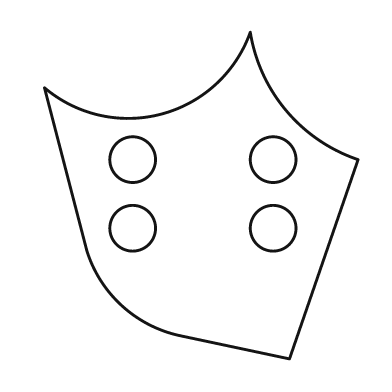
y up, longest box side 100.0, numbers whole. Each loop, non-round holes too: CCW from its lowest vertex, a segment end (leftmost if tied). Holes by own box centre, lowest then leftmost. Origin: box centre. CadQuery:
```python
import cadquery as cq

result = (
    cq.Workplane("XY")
    .moveTo(27.0, -50.0)
    .lineTo(48.0, 11.0)
    .threePointArc((26.0, 26.0), (15.0, 50.0))
    .threePointArc((-12.0, 25.0), (-48.0, 33.0))
    .lineTo(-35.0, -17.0)
    .threePointArc((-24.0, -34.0), (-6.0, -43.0))
    .close()
    .moveTo(-21.0, -10.0)
    .circle(7.0)
    .moveTo(22.0, -10.0)
    .circle(7.0)
    .moveTo(-21.0, 11.0)
    .circle(7.0)
    .moveTo(22.0, 11.0)
    .circle(7.0)
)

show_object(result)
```